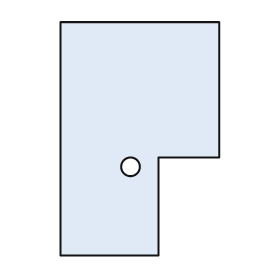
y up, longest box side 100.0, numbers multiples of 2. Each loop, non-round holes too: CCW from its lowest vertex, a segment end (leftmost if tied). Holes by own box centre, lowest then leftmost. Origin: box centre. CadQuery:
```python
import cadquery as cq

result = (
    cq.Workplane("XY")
    .moveTo(-34.0, -50.0)
    .lineTo(8.0, -50.0)
    .lineTo(8.0, -8.0)
    .lineTo(34.0, -8.0)
    .lineTo(34.0, 50.0)
    .lineTo(-34.0, 50.0)
    .close()
    .moveTo(-4.0, -12.0)
    .circle(4.0)
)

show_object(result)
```